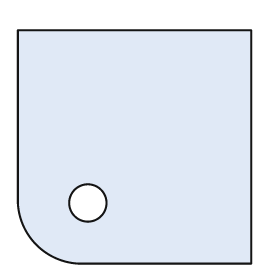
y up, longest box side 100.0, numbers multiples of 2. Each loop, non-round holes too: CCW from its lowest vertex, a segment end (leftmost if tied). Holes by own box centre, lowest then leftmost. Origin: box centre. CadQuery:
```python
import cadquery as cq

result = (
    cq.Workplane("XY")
    .moveTo(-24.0, -50.0)
    .lineTo(50.0, -50.0)
    .lineTo(50.0, 50.0)
    .lineTo(-50.0, 50.0)
    .lineTo(-50.0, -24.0)
    .threePointArc((-42.0, -42.0), (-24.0, -50.0))
    .close()
    .moveTo(-20.0, -24.0)
    .circle(8.0)
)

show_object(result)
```